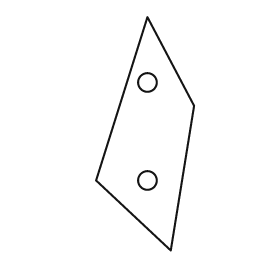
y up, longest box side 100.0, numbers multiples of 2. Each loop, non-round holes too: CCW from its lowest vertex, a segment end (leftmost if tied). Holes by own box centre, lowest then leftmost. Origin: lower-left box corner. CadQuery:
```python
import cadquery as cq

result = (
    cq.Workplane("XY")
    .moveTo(32.0, 0.0)
    .lineTo(42.0, 62.0)
    .lineTo(22.0, 100.0)
    .lineTo(0.0, 30.0)
    .close()
    .moveTo(22.0, 30.0)
    .circle(4.0)
    .moveTo(22.0, 72.0)
    .circle(4.0)
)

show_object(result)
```